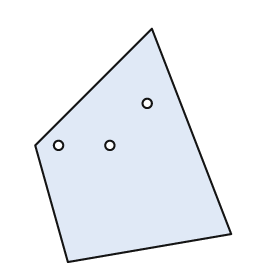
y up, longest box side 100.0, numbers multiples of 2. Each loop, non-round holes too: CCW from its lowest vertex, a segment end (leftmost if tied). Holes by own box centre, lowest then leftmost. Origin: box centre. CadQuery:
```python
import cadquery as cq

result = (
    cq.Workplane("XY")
    .moveTo(-28.0, -50.0)
    .lineTo(42.0, -38.0)
    .lineTo(8.0, 50.0)
    .lineTo(-42.0, 0.0)
    .close()
    .moveTo(-32.0, 0.0)
    .circle(2.0)
    .moveTo(-10.0, 0.0)
    .circle(2.0)
    .moveTo(6.0, 18.0)
    .circle(2.0)
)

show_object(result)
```